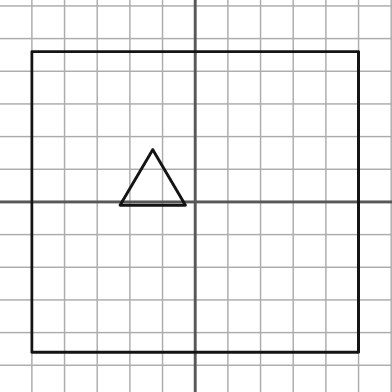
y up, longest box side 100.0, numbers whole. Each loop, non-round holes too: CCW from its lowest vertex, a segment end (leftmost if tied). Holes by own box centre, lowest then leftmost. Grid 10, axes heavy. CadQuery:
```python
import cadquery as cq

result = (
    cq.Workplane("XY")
    .moveTo(-50.0, -46.0)
    .lineTo(50.0, -46.0)
    .lineTo(50.0, 46.0)
    .lineTo(-50.0, 46.0)
    .close()
    .moveTo(-23.0, -1.0)
    .lineTo(-3.0, -1.0)
    .lineTo(-13.0, 16.0)
    .close()
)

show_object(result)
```